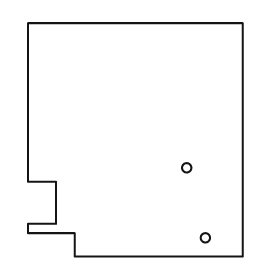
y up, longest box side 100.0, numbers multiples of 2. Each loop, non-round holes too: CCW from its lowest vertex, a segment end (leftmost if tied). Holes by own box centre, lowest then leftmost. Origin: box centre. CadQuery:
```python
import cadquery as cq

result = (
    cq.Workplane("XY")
    .moveTo(-26.0, -50.0)
    .lineTo(46.0, -50.0)
    .lineTo(46.0, 50.0)
    .lineTo(-46.0, 50.0)
    .lineTo(-46.0, -18.0)
    .lineTo(-34.0, -18.0)
    .lineTo(-34.0, -36.0)
    .lineTo(-46.0, -36.0)
    .lineTo(-46.0, -40.0)
    .lineTo(-26.0, -40.0)
    .close()
    .moveTo(30.0, -42.0)
    .circle(2.0)
    .moveTo(22.0, -12.0)
    .circle(2.0)
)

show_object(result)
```